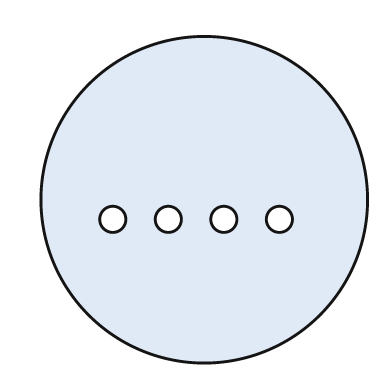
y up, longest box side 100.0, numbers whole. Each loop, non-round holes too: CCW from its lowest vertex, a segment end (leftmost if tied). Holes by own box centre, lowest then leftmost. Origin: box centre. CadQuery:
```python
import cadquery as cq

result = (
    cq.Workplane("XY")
    .moveTo(0.0, 0.0)
    .circle(50.0)
    .moveTo(-28.0, -6.0)
    .circle(4.0)
    .moveTo(-11.0, -6.0)
    .circle(4.0)
    .moveTo(6.0, -6.0)
    .circle(4.0)
    .moveTo(23.0, -6.0)
    .circle(4.0)
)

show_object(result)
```